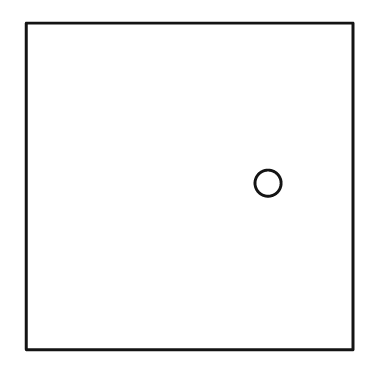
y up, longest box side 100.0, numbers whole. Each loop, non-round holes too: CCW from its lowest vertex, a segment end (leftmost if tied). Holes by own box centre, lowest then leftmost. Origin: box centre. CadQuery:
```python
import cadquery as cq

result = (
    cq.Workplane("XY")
    .moveTo(-50.0, -50.0)
    .lineTo(50.0, -50.0)
    .lineTo(50.0, 50.0)
    .lineTo(-50.0, 50.0)
    .close()
    .moveTo(24.0, 1.0)
    .circle(4.0)
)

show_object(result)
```